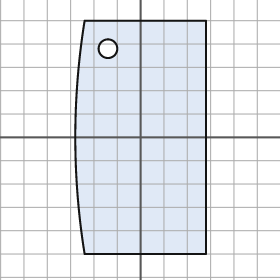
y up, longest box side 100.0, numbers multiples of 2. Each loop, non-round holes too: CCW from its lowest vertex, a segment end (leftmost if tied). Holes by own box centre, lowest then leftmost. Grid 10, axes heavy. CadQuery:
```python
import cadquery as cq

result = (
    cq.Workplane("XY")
    .moveTo(-24.0, -50.0)
    .lineTo(28.0, -50.0)
    .lineTo(28.0, 50.0)
    .lineTo(-24.0, 50.0)
    .threePointArc((-28.0, 0.0), (-24.0, -50.0))
    .close()
    .moveTo(-14.0, 38.0)
    .circle(4.0)
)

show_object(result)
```